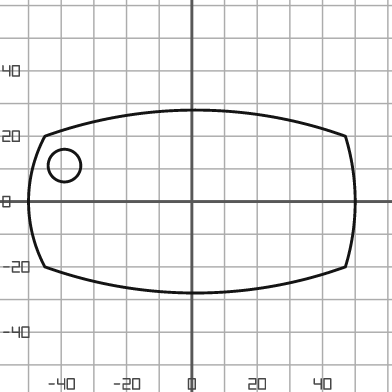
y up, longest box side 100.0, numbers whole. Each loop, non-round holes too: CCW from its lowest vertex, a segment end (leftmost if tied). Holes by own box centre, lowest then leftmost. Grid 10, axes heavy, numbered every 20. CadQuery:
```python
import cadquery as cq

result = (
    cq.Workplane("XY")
    .moveTo(-45.0, -20.0)
    .threePointArc((1.0, -28.0), (47.0, -20.0))
    .threePointArc((50.0, 0.0), (47.0, 20.0))
    .threePointArc((1.0, 28.0), (-45.0, 20.0))
    .threePointArc((-50.0, 0.0), (-45.0, -20.0))
    .close()
    .moveTo(-39.0, 11.0)
    .circle(5.0)
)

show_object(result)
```